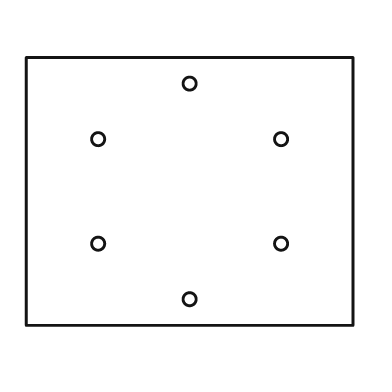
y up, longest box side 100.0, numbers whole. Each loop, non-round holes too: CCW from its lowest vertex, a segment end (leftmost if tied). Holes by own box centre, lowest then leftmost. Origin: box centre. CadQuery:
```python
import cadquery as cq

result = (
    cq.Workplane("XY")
    .moveTo(-50.0, -41.0)
    .lineTo(50.0, -41.0)
    .lineTo(50.0, 41.0)
    .lineTo(-50.0, 41.0)
    .close()
    .moveTo(0.0, -33.0)
    .circle(2.0)
    .moveTo(-28.0, -16.0)
    .circle(2.0)
    .moveTo(28.0, -16.0)
    .circle(2.0)
    .moveTo(-28.0, 16.0)
    .circle(2.0)
    .moveTo(28.0, 16.0)
    .circle(2.0)
    .moveTo(0.0, 33.0)
    .circle(2.0)
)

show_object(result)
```